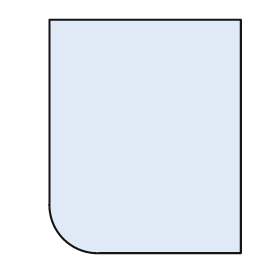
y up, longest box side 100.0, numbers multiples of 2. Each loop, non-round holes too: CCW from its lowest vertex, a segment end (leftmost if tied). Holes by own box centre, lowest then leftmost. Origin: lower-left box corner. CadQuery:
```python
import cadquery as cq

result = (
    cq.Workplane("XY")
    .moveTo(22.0, 0.0)
    .lineTo(82.0, 0.0)
    .lineTo(82.0, 100.0)
    .lineTo(0.0, 100.0)
    .lineTo(0.0, 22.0)
    .threePointArc((6.0, 6.0), (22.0, 0.0))
    .close()
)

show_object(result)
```